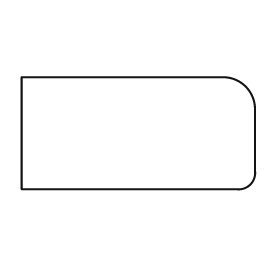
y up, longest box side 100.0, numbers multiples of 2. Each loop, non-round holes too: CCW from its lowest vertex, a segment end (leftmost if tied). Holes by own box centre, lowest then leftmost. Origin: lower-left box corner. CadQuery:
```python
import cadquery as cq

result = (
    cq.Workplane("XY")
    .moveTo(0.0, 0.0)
    .lineTo(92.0, 0.0)
    .threePointArc((98.0, 2.0), (100.0, 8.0))
    .lineTo(100.0, 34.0)
    .threePointArc((96.0, 44.0), (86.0, 48.0))
    .lineTo(0.0, 48.0)
    .close()
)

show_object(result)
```